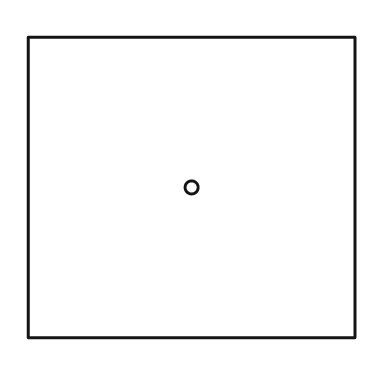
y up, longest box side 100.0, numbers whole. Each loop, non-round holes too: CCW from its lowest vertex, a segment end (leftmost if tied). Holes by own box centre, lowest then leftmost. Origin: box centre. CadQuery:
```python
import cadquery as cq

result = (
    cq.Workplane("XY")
    .moveTo(-50.0, -46.0)
    .lineTo(50.0, -46.0)
    .lineTo(50.0, 46.0)
    .lineTo(-50.0, 46.0)
    .close()
    .moveTo(0.0, 0.0)
    .circle(2.0)
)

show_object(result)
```